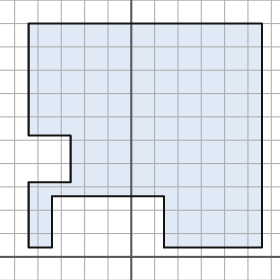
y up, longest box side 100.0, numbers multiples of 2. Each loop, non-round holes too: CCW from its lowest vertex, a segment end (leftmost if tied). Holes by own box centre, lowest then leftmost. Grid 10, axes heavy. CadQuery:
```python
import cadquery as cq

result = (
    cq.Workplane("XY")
    .moveTo(-44.0, 4.0)
    .lineTo(-34.0, 4.0)
    .lineTo(-34.0, 26.0)
    .lineTo(14.0, 26.0)
    .lineTo(14.0, 4.0)
    .lineTo(56.0, 4.0)
    .lineTo(56.0, 100.0)
    .lineTo(-44.0, 100.0)
    .lineTo(-44.0, 52.0)
    .lineTo(-26.0, 52.0)
    .lineTo(-26.0, 32.0)
    .lineTo(-44.0, 32.0)
    .close()
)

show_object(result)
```